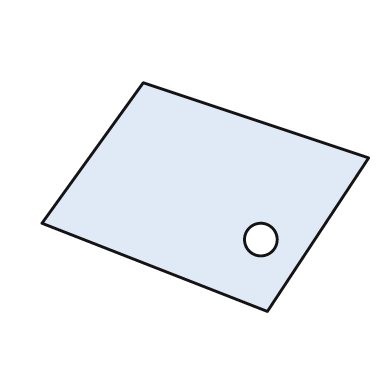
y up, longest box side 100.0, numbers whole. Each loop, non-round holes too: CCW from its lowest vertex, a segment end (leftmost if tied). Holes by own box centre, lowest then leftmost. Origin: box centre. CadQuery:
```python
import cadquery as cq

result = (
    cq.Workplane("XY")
    .moveTo(19.0, -35.0)
    .lineTo(50.0, 12.0)
    .lineTo(-19.0, 35.0)
    .lineTo(-50.0, -8.0)
    .close()
    .moveTo(17.0, -13.0)
    .circle(5.0)
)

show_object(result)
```